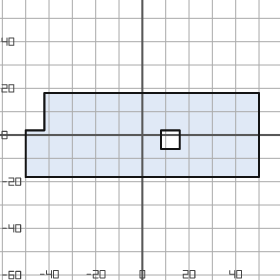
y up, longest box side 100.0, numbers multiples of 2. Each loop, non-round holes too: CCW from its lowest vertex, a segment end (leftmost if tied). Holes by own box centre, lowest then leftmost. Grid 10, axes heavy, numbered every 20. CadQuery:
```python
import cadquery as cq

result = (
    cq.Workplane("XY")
    .moveTo(-50.0, -18.0)
    .lineTo(50.0, -18.0)
    .lineTo(50.0, 18.0)
    .lineTo(-42.0, 18.0)
    .lineTo(-42.0, 2.0)
    .lineTo(-50.0, 2.0)
    .close()
    .moveTo(8.0, -6.0)
    .lineTo(16.0, -6.0)
    .lineTo(16.0, 2.0)
    .lineTo(8.0, 2.0)
    .close()
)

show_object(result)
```